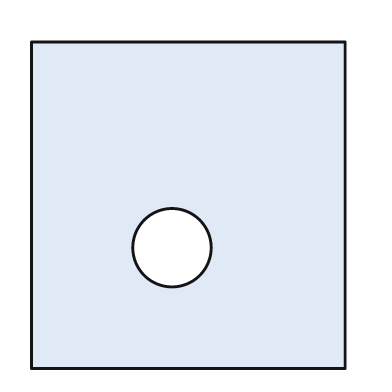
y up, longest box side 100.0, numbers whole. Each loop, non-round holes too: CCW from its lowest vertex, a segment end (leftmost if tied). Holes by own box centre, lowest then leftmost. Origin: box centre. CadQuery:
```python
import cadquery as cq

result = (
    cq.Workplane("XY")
    .moveTo(-48.0, -50.0)
    .lineTo(48.0, -50.0)
    .lineTo(48.0, 50.0)
    .lineTo(-48.0, 50.0)
    .close()
    .moveTo(-5.0, -13.0)
    .circle(12.0)
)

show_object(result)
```